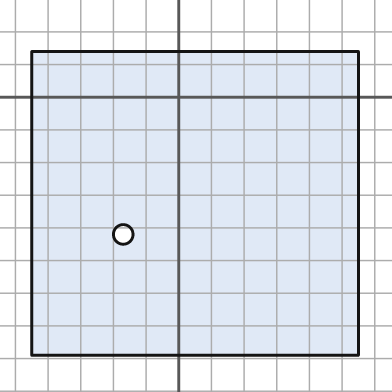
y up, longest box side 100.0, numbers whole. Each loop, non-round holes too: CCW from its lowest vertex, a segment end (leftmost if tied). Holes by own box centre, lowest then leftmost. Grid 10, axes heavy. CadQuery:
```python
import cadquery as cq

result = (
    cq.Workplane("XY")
    .moveTo(-45.0, -79.0)
    .lineTo(55.0, -79.0)
    .lineTo(55.0, 14.0)
    .lineTo(-45.0, 14.0)
    .close()
    .moveTo(-17.0, -42.0)
    .circle(3.0)
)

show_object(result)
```